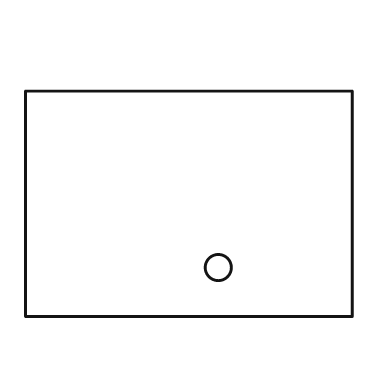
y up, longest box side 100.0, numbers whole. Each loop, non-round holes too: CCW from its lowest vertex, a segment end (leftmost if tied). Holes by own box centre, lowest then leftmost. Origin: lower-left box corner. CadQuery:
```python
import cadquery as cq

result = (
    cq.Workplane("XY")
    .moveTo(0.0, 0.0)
    .lineTo(100.0, 0.0)
    .lineTo(100.0, 69.0)
    .lineTo(0.0, 69.0)
    .close()
    .moveTo(59.0, 15.0)
    .circle(4.0)
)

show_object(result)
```